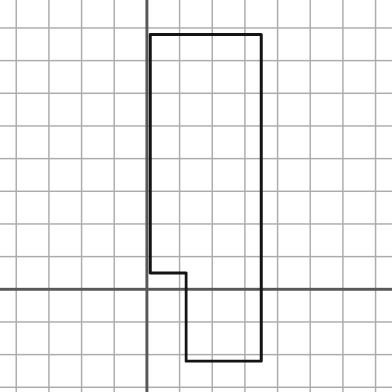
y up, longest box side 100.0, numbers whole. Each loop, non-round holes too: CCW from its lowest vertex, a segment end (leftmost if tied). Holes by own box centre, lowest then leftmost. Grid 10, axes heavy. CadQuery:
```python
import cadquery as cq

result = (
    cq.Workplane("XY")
    .moveTo(12.0, -22.0)
    .lineTo(35.0, -22.0)
    .lineTo(35.0, 78.0)
    .lineTo(1.0, 78.0)
    .lineTo(1.0, 5.0)
    .lineTo(12.0, 5.0)
    .close()
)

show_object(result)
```